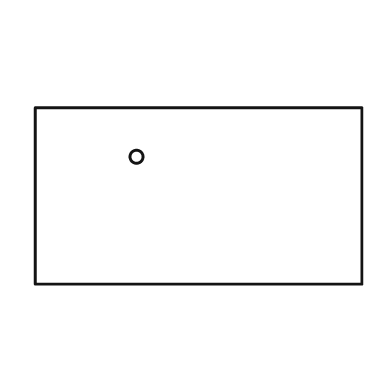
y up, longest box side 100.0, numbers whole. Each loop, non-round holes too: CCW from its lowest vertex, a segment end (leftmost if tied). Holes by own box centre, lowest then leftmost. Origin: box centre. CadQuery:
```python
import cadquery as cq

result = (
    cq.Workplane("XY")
    .moveTo(-50.0, -27.0)
    .lineTo(50.0, -27.0)
    .lineTo(50.0, 27.0)
    .lineTo(-50.0, 27.0)
    .close()
    .moveTo(-19.0, 12.0)
    .circle(2.0)
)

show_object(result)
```